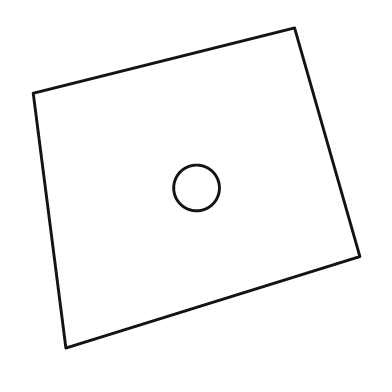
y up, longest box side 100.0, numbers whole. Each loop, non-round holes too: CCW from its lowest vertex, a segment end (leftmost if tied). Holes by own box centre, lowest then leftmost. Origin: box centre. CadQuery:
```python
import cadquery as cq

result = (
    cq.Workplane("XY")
    .moveTo(-40.0, -49.0)
    .lineTo(50.0, -21.0)
    .lineTo(30.0, 49.0)
    .lineTo(-50.0, 29.0)
    .close()
    .moveTo(0.0, 0.0)
    .circle(7.0)
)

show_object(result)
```